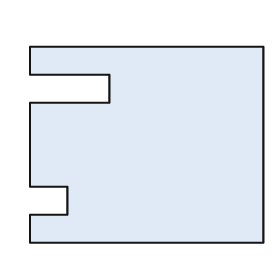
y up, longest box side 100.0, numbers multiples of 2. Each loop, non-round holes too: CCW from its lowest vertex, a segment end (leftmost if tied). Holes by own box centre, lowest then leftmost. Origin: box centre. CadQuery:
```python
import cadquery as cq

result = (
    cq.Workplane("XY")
    .moveTo(-50.0, -42.0)
    .lineTo(50.0, -42.0)
    .lineTo(50.0, 42.0)
    .lineTo(-50.0, 42.0)
    .lineTo(-50.0, 30.0)
    .lineTo(-16.0, 30.0)
    .lineTo(-16.0, 18.0)
    .lineTo(-50.0, 18.0)
    .lineTo(-50.0, -18.0)
    .lineTo(-34.0, -18.0)
    .lineTo(-34.0, -30.0)
    .lineTo(-50.0, -30.0)
    .close()
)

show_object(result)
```